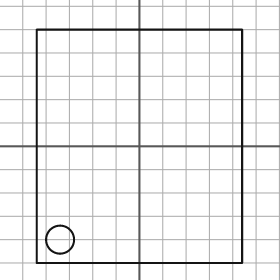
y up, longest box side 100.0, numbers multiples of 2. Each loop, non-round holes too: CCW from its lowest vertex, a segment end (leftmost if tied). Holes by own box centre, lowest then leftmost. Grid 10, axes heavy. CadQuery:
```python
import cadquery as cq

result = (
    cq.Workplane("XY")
    .moveTo(-44.0, -50.0)
    .lineTo(44.0, -50.0)
    .lineTo(44.0, 50.0)
    .lineTo(-44.0, 50.0)
    .close()
    .moveTo(-34.0, -40.0)
    .circle(6.0)
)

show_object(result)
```